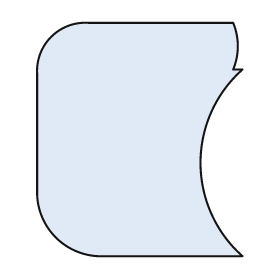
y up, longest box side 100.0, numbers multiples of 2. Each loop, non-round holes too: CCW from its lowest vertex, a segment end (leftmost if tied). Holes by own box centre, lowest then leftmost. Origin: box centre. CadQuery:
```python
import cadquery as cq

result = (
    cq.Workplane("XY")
    .moveTo(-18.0, -50.0)
    .lineTo(44.0, -50.0)
    .threePointArc((26.0, -10.0), (44.0, 30.0))
    .lineTo(40.0, 30.0)
    .threePointArc((42.0, 40.0), (40.0, 50.0))
    .lineTo(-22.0, 50.0)
    .threePointArc((-38.0, 44.0), (-44.0, 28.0))
    .lineTo(-44.0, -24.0)
    .threePointArc((-36.0, -42.0), (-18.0, -50.0))
    .close()
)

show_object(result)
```